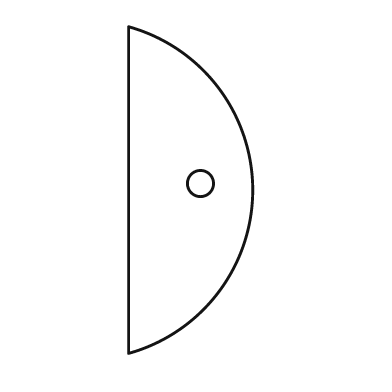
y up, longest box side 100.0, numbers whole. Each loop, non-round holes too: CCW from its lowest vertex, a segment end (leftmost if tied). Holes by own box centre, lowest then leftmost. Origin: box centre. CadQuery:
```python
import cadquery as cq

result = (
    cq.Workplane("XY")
    .moveTo(-19.0, -50.0)
    .threePointArc((19.0, 0.0), (-19.0, 50.0))
    .close()
    .moveTo(3.0, 2.0)
    .circle(4.0)
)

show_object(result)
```